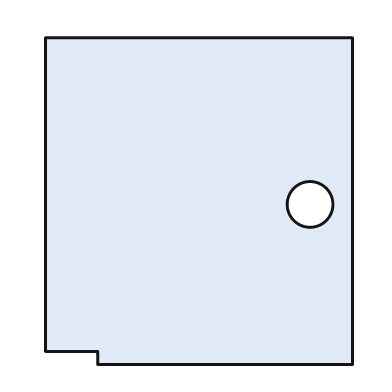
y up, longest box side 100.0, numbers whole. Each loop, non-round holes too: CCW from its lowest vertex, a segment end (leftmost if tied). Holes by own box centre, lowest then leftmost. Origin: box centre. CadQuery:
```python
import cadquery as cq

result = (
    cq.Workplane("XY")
    .moveTo(-31.0, -50.0)
    .lineTo(47.0, -50.0)
    .lineTo(47.0, 50.0)
    .lineTo(-47.0, 50.0)
    .lineTo(-47.0, -46.0)
    .lineTo(-31.0, -46.0)
    .close()
    .moveTo(34.0, -1.0)
    .circle(7.0)
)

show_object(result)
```